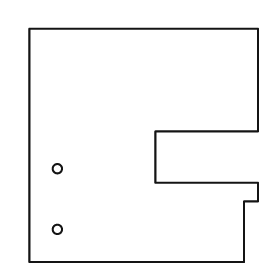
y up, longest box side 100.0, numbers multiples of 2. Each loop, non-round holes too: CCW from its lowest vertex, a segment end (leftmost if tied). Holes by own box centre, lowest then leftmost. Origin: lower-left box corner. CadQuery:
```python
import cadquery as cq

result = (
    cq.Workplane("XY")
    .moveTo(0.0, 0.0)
    .lineTo(92.0, 0.0)
    .lineTo(92.0, 26.0)
    .lineTo(98.0, 26.0)
    .lineTo(98.0, 34.0)
    .lineTo(54.0, 34.0)
    .lineTo(54.0, 56.0)
    .lineTo(98.0, 56.0)
    .lineTo(98.0, 100.0)
    .lineTo(0.0, 100.0)
    .close()
    .moveTo(12.0, 14.0)
    .circle(2.0)
    .moveTo(12.0, 40.0)
    .circle(2.0)
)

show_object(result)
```